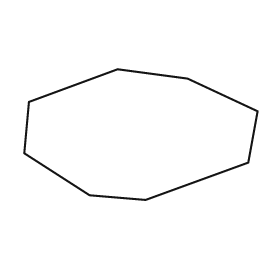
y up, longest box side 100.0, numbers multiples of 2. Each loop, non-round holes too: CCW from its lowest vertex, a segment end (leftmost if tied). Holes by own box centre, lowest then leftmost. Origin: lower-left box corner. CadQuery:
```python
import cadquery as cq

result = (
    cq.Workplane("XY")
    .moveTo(52.0, 0.0)
    .lineTo(96.0, 16.0)
    .lineTo(100.0, 38.0)
    .lineTo(70.0, 52.0)
    .lineTo(40.0, 56.0)
    .lineTo(2.0, 42.0)
    .lineTo(0.0, 20.0)
    .lineTo(28.0, 2.0)
    .close()
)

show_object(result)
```